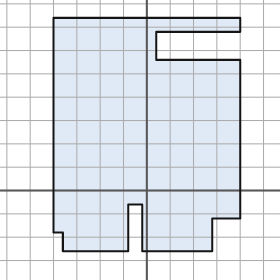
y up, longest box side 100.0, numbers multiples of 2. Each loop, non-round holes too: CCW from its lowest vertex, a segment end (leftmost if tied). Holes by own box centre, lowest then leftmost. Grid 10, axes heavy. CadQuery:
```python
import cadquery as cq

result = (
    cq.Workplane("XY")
    .moveTo(-36.0, -26.0)
    .lineTo(-8.0, -26.0)
    .lineTo(-8.0, -6.0)
    .lineTo(-2.0, -6.0)
    .lineTo(-2.0, -26.0)
    .lineTo(28.0, -26.0)
    .lineTo(28.0, -12.0)
    .lineTo(40.0, -12.0)
    .lineTo(40.0, 56.0)
    .lineTo(4.0, 56.0)
    .lineTo(4.0, 68.0)
    .lineTo(40.0, 68.0)
    .lineTo(40.0, 74.0)
    .lineTo(-40.0, 74.0)
    .lineTo(-40.0, -18.0)
    .lineTo(-36.0, -18.0)
    .close()
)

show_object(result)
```